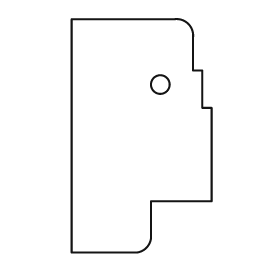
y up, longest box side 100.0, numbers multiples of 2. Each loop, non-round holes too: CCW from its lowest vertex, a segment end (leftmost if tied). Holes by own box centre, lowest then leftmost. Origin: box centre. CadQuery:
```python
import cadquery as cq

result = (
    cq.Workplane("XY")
    .moveTo(-30.0, -50.0)
    .lineTo(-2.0, -50.0)
    .threePointArc((2.0, -48.0), (4.0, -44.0))
    .lineTo(4.0, -28.0)
    .lineTo(30.0, -28.0)
    .lineTo(30.0, 12.0)
    .lineTo(26.0, 12.0)
    .lineTo(26.0, 28.0)
    .lineTo(22.0, 28.0)
    .lineTo(22.0, 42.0)
    .threePointArc((20.0, 48.0), (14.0, 50.0))
    .lineTo(-30.0, 50.0)
    .close()
    .moveTo(8.0, 22.0)
    .circle(4.0)
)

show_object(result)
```